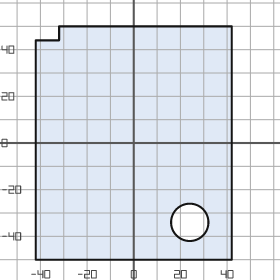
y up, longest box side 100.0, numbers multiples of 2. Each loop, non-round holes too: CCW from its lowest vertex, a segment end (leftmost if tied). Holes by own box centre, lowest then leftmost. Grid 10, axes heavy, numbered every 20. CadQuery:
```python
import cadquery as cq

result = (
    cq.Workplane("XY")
    .moveTo(-42.0, -50.0)
    .lineTo(42.0, -50.0)
    .lineTo(42.0, 50.0)
    .lineTo(-32.0, 50.0)
    .lineTo(-32.0, 44.0)
    .lineTo(-42.0, 44.0)
    .close()
    .moveTo(24.0, -34.0)
    .circle(8.0)
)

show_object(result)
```